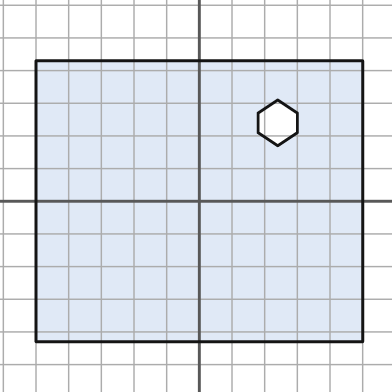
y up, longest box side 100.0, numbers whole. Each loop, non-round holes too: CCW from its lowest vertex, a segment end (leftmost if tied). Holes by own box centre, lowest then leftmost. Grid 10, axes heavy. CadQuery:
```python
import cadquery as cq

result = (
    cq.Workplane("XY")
    .moveTo(-50.0, -43.0)
    .lineTo(50.0, -43.0)
    .lineTo(50.0, 43.0)
    .lineTo(-50.0, 43.0)
    .close()
    .moveTo(24.0, 17.0)
    .lineTo(30.0, 21.0)
    .lineTo(30.0, 27.0)
    .lineTo(24.0, 31.0)
    .lineTo(18.0, 27.0)
    .lineTo(18.0, 21.0)
    .close()
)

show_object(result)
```